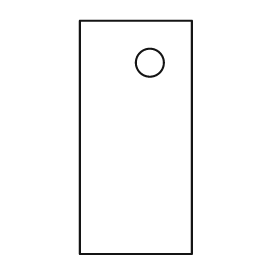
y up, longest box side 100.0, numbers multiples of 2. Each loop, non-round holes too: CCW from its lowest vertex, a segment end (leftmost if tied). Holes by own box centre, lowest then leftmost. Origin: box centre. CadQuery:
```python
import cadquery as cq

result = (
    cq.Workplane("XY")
    .moveTo(-24.0, -50.0)
    .lineTo(24.0, -50.0)
    .lineTo(24.0, 50.0)
    .lineTo(-24.0, 50.0)
    .close()
    .moveTo(6.0, 32.0)
    .circle(6.0)
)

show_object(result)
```